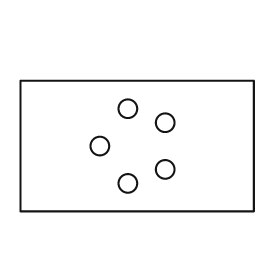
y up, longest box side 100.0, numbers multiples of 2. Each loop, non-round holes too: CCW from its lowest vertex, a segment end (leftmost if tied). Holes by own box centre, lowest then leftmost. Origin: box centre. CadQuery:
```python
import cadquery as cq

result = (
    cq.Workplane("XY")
    .moveTo(-50.0, -28.0)
    .lineTo(50.0, -28.0)
    .lineTo(50.0, 28.0)
    .lineTo(-50.0, 28.0)
    .close()
    .moveTo(-4.0, -16.0)
    .circle(4.0)
    .moveTo(12.0, -10.0)
    .circle(4.0)
    .moveTo(-16.0, 0.0)
    .circle(4.0)
    .moveTo(12.0, 10.0)
    .circle(4.0)
    .moveTo(-4.0, 16.0)
    .circle(4.0)
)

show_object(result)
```